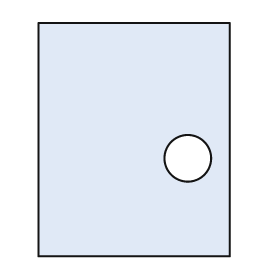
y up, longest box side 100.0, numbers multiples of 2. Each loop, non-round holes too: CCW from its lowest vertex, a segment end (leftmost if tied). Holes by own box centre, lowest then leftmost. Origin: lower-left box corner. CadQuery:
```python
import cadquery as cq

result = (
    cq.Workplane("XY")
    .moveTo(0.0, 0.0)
    .lineTo(82.0, 0.0)
    .lineTo(82.0, 100.0)
    .lineTo(0.0, 100.0)
    .close()
    .moveTo(64.0, 42.0)
    .circle(10.0)
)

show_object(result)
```